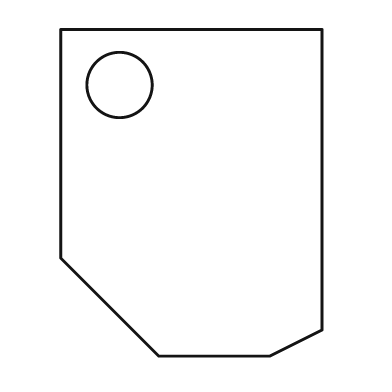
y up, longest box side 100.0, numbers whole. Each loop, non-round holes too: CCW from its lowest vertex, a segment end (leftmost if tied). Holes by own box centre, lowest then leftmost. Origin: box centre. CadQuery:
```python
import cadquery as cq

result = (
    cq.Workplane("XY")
    .moveTo(-10.0, -50.0)
    .lineTo(24.0, -50.0)
    .lineTo(40.0, -42.0)
    .lineTo(40.0, 50.0)
    .lineTo(-40.0, 50.0)
    .lineTo(-40.0, -20.0)
    .close()
    .moveTo(-22.0, 33.0)
    .circle(10.0)
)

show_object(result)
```